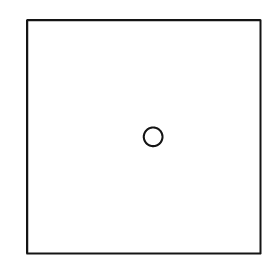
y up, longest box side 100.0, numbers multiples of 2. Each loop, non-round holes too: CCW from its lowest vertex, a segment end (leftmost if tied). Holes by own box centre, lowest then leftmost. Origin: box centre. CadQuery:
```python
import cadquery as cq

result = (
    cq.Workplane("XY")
    .moveTo(-50.0, -50.0)
    .lineTo(50.0, -50.0)
    .lineTo(50.0, 50.0)
    .lineTo(-50.0, 50.0)
    .close()
    .moveTo(4.0, 0.0)
    .circle(4.0)
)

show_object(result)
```